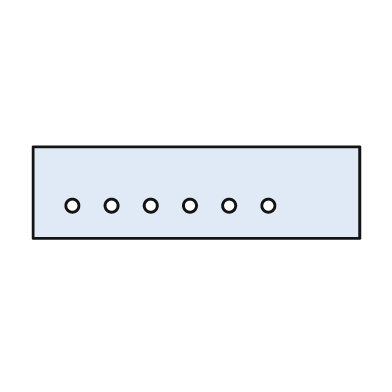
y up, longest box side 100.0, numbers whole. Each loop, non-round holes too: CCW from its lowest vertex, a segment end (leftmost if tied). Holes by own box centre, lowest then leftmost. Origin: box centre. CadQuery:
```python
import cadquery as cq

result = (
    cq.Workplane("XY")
    .moveTo(-50.0, -14.0)
    .lineTo(50.0, -14.0)
    .lineTo(50.0, 14.0)
    .lineTo(-50.0, 14.0)
    .close()
    .moveTo(-38.0, -4.0)
    .circle(2.0)
    .moveTo(-26.0, -4.0)
    .circle(2.0)
    .moveTo(-14.0, -4.0)
    .circle(2.0)
    .moveTo(-2.0, -4.0)
    .circle(2.0)
    .moveTo(10.0, -4.0)
    .circle(2.0)
    .moveTo(22.0, -4.0)
    .circle(2.0)
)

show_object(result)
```